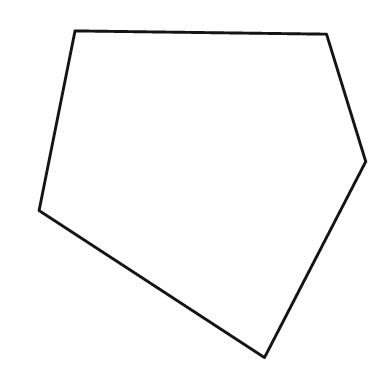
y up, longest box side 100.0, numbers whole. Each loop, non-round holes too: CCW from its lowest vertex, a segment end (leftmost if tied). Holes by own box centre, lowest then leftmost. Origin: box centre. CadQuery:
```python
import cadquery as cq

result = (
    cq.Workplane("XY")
    .moveTo(19.0, -50.0)
    .lineTo(50.0, 10.0)
    .lineTo(38.0, 49.0)
    .lineTo(-39.0, 50.0)
    .lineTo(-50.0, -5.0)
    .close()
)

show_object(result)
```